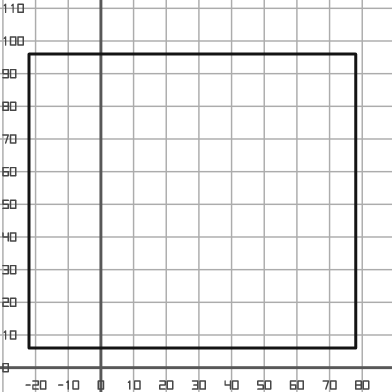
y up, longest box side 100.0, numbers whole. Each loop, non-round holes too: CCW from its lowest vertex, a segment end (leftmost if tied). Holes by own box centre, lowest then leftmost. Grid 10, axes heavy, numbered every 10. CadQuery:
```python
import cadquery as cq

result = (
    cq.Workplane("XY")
    .moveTo(-22.0, 6.0)
    .lineTo(78.0, 6.0)
    .lineTo(78.0, 96.0)
    .lineTo(-22.0, 96.0)
    .close()
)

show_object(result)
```